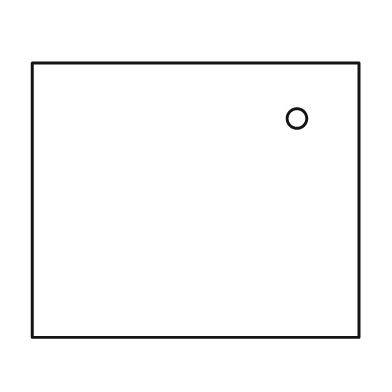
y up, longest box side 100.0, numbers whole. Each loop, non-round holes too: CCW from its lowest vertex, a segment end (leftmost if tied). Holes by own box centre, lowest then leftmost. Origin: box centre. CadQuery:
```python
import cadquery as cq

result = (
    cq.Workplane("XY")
    .moveTo(-50.0, -42.0)
    .lineTo(50.0, -42.0)
    .lineTo(50.0, 42.0)
    .lineTo(-50.0, 42.0)
    .close()
    .moveTo(31.0, 25.0)
    .circle(3.0)
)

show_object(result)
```